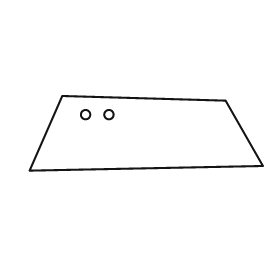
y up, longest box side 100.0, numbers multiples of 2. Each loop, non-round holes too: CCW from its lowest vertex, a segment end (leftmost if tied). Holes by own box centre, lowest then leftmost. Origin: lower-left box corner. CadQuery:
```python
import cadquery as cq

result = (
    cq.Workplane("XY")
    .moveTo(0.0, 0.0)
    .lineTo(100.0, 2.0)
    .lineTo(84.0, 30.0)
    .lineTo(14.0, 32.0)
    .close()
    .moveTo(24.0, 24.0)
    .circle(2.0)
    .moveTo(34.0, 24.0)
    .circle(2.0)
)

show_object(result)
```